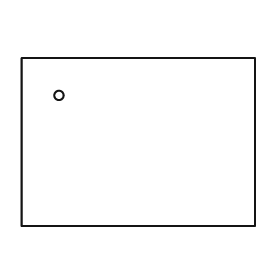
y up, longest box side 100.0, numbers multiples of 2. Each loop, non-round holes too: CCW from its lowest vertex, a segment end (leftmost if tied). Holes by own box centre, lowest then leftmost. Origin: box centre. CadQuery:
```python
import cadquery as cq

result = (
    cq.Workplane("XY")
    .moveTo(-50.0, -36.0)
    .lineTo(50.0, -36.0)
    .lineTo(50.0, 36.0)
    .lineTo(-50.0, 36.0)
    .close()
    .moveTo(-34.0, 20.0)
    .circle(2.0)
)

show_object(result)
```